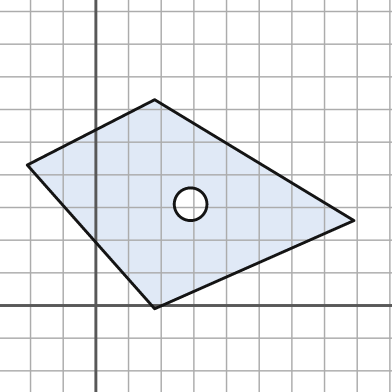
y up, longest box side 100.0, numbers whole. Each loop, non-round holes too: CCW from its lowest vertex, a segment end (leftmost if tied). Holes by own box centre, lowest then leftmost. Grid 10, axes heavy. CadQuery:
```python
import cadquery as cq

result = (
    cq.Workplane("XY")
    .moveTo(18.0, -1.0)
    .lineTo(79.0, 26.0)
    .lineTo(18.0, 63.0)
    .lineTo(-21.0, 43.0)
    .close()
    .moveTo(29.0, 31.0)
    .circle(5.0)
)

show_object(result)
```